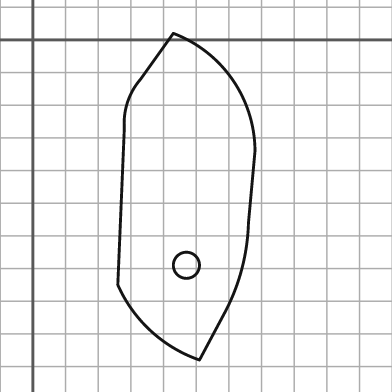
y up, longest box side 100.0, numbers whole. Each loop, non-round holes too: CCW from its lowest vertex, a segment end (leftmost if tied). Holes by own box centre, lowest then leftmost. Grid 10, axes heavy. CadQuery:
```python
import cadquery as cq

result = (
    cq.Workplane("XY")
    .moveTo(51.0, -98.0)
    .lineTo(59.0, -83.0)
    .threePointArc((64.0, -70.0), (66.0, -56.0))
    .lineTo(68.0, -34.0)
    .threePointArc((61.0, -12.0), (43.0, 2.0))
    .lineTo(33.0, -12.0)
    .threePointArc((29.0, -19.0), (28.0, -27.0))
    .lineTo(26.0, -75.0)
    .threePointArc((36.0, -89.0), (51.0, -98.0))
    .close()
    .moveTo(47.0, -69.0)
    .circle(4.0)
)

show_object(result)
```